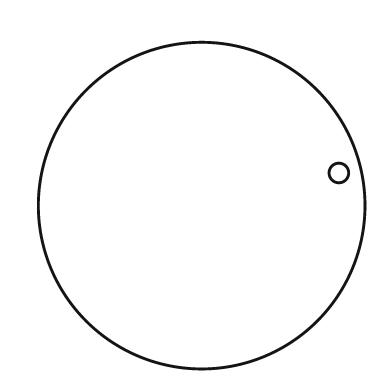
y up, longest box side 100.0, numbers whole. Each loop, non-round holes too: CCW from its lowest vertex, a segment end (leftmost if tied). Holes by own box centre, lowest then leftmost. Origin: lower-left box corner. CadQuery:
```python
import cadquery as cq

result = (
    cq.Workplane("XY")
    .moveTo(50.0, 50.0)
    .circle(50.0)
    .moveTo(92.0, 60.0)
    .circle(3.0)
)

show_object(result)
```